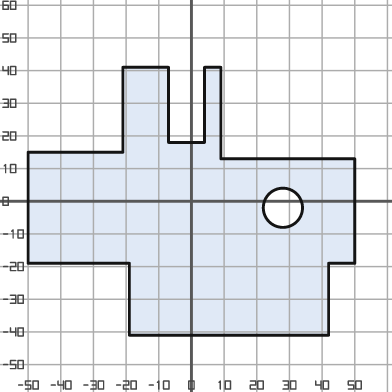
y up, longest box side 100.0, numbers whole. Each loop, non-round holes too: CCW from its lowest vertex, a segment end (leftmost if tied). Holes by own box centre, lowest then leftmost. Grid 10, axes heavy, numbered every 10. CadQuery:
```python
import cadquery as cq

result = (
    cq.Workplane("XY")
    .moveTo(-19.0, -41.0)
    .lineTo(42.0, -41.0)
    .lineTo(42.0, -19.0)
    .lineTo(50.0, -19.0)
    .lineTo(50.0, 13.0)
    .lineTo(9.0, 13.0)
    .lineTo(9.0, 41.0)
    .lineTo(4.0, 41.0)
    .lineTo(4.0, 18.0)
    .lineTo(-7.0, 18.0)
    .lineTo(-7.0, 41.0)
    .lineTo(-21.0, 41.0)
    .lineTo(-21.0, 15.0)
    .lineTo(-50.0, 15.0)
    .lineTo(-50.0, -19.0)
    .lineTo(-19.0, -19.0)
    .close()
    .moveTo(28.0, -2.0)
    .circle(6.0)
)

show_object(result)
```